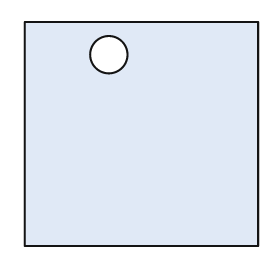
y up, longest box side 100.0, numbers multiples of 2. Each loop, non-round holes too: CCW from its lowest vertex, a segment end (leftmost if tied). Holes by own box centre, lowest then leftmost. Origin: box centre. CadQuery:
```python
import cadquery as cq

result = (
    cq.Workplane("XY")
    .moveTo(-50.0, -48.0)
    .lineTo(50.0, -48.0)
    .lineTo(50.0, 48.0)
    .lineTo(-50.0, 48.0)
    .close()
    .moveTo(-14.0, 34.0)
    .circle(8.0)
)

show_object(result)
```